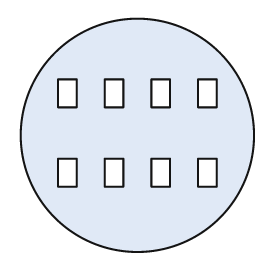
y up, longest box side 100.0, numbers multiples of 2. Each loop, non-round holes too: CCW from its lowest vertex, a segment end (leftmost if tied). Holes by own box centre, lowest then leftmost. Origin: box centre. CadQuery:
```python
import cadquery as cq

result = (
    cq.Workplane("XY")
    .moveTo(0.0, 0.0)
    .circle(50.0)
    .moveTo(-34.0, -22.0)
    .lineTo(-26.0, -22.0)
    .lineTo(-26.0, -10.0)
    .lineTo(-34.0, -10.0)
    .close()
    .moveTo(-14.0, -22.0)
    .lineTo(-6.0, -22.0)
    .lineTo(-6.0, -10.0)
    .lineTo(-14.0, -10.0)
    .close()
    .moveTo(6.0, -22.0)
    .lineTo(14.0, -22.0)
    .lineTo(14.0, -10.0)
    .lineTo(6.0, -10.0)
    .close()
    .moveTo(26.0, -22.0)
    .lineTo(34.0, -22.0)
    .lineTo(34.0, -10.0)
    .lineTo(26.0, -10.0)
    .close()
    .moveTo(-34.0, 12.0)
    .lineTo(-26.0, 12.0)
    .lineTo(-26.0, 24.0)
    .lineTo(-34.0, 24.0)
    .close()
    .moveTo(-14.0, 12.0)
    .lineTo(-6.0, 12.0)
    .lineTo(-6.0, 24.0)
    .lineTo(-14.0, 24.0)
    .close()
    .moveTo(6.0, 12.0)
    .lineTo(14.0, 12.0)
    .lineTo(14.0, 24.0)
    .lineTo(6.0, 24.0)
    .close()
    .moveTo(26.0, 12.0)
    .lineTo(34.0, 12.0)
    .lineTo(34.0, 24.0)
    .lineTo(26.0, 24.0)
    .close()
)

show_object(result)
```